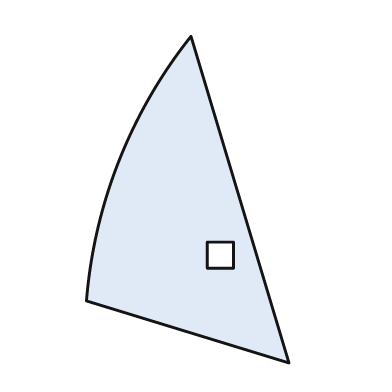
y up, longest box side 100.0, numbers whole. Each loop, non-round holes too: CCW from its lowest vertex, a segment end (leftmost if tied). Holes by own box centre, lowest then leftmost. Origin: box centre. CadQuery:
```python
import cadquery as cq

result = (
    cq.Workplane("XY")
    .moveTo(31.0, -50.0)
    .lineTo(1.0, 50.0)
    .threePointArc((-21.0, 12.0), (-31.0, -31.0))
    .close()
    .moveTo(6.0, -21.0)
    .lineTo(14.0, -21.0)
    .lineTo(14.0, -13.0)
    .lineTo(6.0, -13.0)
    .close()
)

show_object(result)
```